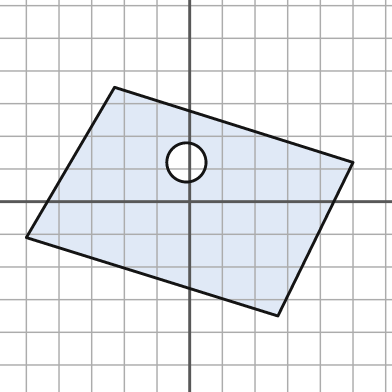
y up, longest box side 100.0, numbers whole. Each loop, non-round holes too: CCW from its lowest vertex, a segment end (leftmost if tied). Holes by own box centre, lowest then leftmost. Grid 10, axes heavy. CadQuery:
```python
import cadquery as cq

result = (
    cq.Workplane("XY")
    .moveTo(27.0, -35.0)
    .lineTo(50.0, 12.0)
    .lineTo(-23.0, 35.0)
    .lineTo(-50.0, -11.0)
    .close()
    .moveTo(-1.0, 12.0)
    .circle(6.0)
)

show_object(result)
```